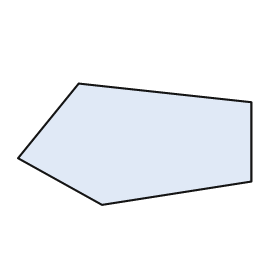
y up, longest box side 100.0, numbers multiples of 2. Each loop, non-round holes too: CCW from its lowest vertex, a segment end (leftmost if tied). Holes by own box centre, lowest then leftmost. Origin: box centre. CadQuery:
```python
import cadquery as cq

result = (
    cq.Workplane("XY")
    .moveTo(-14.0, -26.0)
    .lineTo(50.0, -16.0)
    .lineTo(50.0, 18.0)
    .lineTo(-24.0, 26.0)
    .lineTo(-50.0, -6.0)
    .close()
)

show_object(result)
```